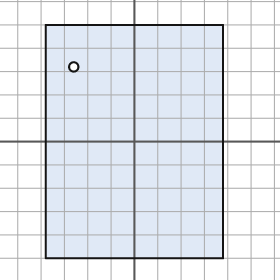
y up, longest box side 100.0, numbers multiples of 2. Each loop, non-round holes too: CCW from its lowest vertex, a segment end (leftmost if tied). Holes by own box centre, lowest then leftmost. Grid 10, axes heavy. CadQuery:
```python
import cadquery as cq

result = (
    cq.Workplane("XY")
    .moveTo(-38.0, -50.0)
    .lineTo(38.0, -50.0)
    .lineTo(38.0, 50.0)
    .lineTo(-38.0, 50.0)
    .close()
    .moveTo(-26.0, 32.0)
    .circle(2.0)
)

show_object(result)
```